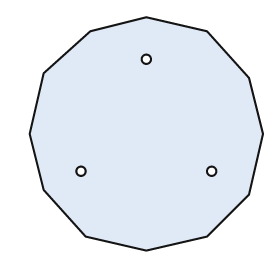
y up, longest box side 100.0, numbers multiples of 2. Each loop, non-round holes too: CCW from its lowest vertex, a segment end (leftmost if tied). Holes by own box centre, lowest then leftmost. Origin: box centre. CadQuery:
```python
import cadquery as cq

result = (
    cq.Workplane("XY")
    .moveTo(0.0, -50.0)
    .lineTo(26.0, -44.0)
    .lineTo(44.0, -26.0)
    .lineTo(50.0, 0.0)
    .lineTo(44.0, 24.0)
    .lineTo(26.0, 44.0)
    .lineTo(0.0, 50.0)
    .lineTo(-24.0, 44.0)
    .lineTo(-44.0, 26.0)
    .lineTo(-50.0, 0.0)
    .lineTo(-44.0, -24.0)
    .lineTo(-26.0, -44.0)
    .close()
    .moveTo(-28.0, -16.0)
    .circle(2.0)
    .moveTo(28.0, -16.0)
    .circle(2.0)
    .moveTo(0.0, 32.0)
    .circle(2.0)
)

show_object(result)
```